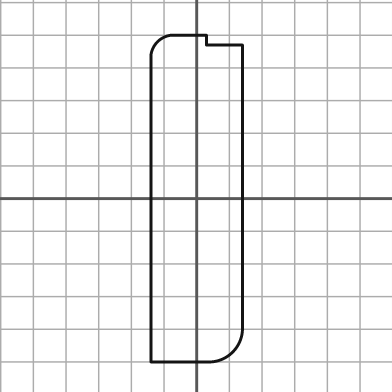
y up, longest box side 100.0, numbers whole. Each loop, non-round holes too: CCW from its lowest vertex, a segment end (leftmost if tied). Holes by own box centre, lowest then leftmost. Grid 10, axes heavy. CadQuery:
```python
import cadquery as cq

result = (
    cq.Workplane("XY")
    .moveTo(-14.0, -50.0)
    .lineTo(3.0, -50.0)
    .threePointArc((11.0, -47.0), (14.0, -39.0))
    .lineTo(14.0, 47.0)
    .lineTo(3.0, 47.0)
    .lineTo(3.0, 50.0)
    .lineTo(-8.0, 50.0)
    .threePointArc((-12.0, 48.0), (-14.0, 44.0))
    .close()
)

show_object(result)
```